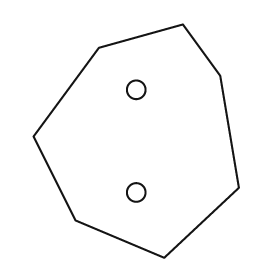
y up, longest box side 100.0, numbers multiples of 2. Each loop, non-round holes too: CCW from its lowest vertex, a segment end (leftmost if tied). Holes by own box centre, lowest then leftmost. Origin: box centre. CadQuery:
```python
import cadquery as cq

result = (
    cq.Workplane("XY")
    .moveTo(12.0, -50.0)
    .lineTo(44.0, -20.0)
    .lineTo(36.0, 28.0)
    .lineTo(20.0, 50.0)
    .lineTo(-16.0, 40.0)
    .lineTo(-44.0, 2.0)
    .lineTo(-26.0, -34.0)
    .close()
    .moveTo(0.0, -22.0)
    .circle(4.0)
    .moveTo(0.0, 22.0)
    .circle(4.0)
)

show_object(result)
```